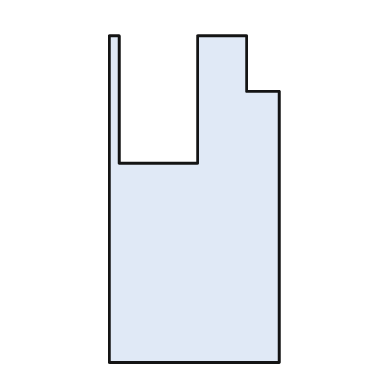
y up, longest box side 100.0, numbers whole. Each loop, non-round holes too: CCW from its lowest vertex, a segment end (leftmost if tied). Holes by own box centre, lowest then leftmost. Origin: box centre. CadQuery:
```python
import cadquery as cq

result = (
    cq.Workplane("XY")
    .moveTo(-26.0, -50.0)
    .lineTo(26.0, -50.0)
    .lineTo(26.0, 33.0)
    .lineTo(16.0, 33.0)
    .lineTo(16.0, 50.0)
    .lineTo(1.0, 50.0)
    .lineTo(1.0, 11.0)
    .lineTo(-23.0, 11.0)
    .lineTo(-23.0, 50.0)
    .lineTo(-26.0, 50.0)
    .close()
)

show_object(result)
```